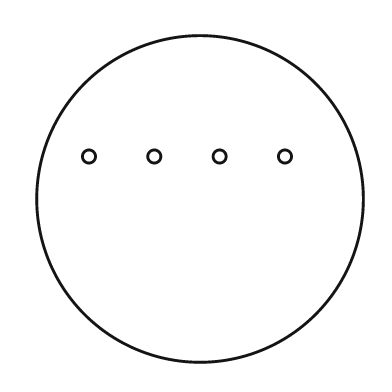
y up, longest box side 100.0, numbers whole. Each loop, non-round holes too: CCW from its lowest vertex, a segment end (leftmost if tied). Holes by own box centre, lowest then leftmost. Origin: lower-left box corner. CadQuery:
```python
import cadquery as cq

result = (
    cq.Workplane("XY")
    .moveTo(50.0, 50.0)
    .circle(50.0)
    .moveTo(16.0, 63.0)
    .circle(2.0)
    .moveTo(36.0, 63.0)
    .circle(2.0)
    .moveTo(56.0, 63.0)
    .circle(2.0)
    .moveTo(76.0, 63.0)
    .circle(2.0)
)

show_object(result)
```